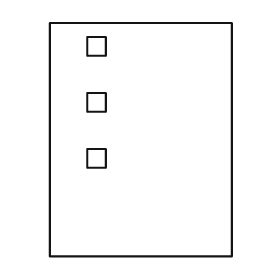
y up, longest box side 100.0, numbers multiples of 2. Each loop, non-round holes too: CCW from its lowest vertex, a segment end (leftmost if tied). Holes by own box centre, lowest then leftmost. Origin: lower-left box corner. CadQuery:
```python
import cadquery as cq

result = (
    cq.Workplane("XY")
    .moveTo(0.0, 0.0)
    .lineTo(78.0, 0.0)
    .lineTo(78.0, 100.0)
    .lineTo(0.0, 100.0)
    .close()
    .moveTo(16.0, 38.0)
    .lineTo(24.0, 38.0)
    .lineTo(24.0, 46.0)
    .lineTo(16.0, 46.0)
    .close()
    .moveTo(16.0, 62.0)
    .lineTo(24.0, 62.0)
    .lineTo(24.0, 70.0)
    .lineTo(16.0, 70.0)
    .close()
    .moveTo(16.0, 86.0)
    .lineTo(24.0, 86.0)
    .lineTo(24.0, 94.0)
    .lineTo(16.0, 94.0)
    .close()
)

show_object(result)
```